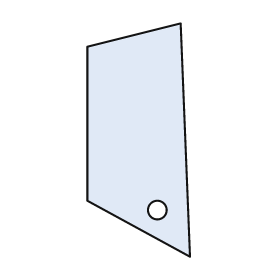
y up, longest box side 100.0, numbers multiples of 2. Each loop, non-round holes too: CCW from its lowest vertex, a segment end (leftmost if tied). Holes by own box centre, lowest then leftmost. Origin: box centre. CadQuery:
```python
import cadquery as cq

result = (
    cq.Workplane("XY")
    .moveTo(22.0, -50.0)
    .lineTo(18.0, 50.0)
    .lineTo(-22.0, 40.0)
    .lineTo(-22.0, -26.0)
    .close()
    .moveTo(8.0, -30.0)
    .circle(4.0)
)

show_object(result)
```